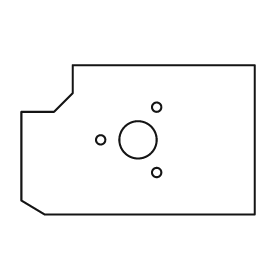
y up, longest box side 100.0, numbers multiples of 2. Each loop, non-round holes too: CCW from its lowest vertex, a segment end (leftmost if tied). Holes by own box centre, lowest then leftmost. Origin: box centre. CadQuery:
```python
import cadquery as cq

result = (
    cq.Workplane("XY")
    .moveTo(-40.0, -32.0)
    .lineTo(50.0, -32.0)
    .lineTo(50.0, 32.0)
    .lineTo(-28.0, 32.0)
    .lineTo(-28.0, 20.0)
    .lineTo(-36.0, 12.0)
    .lineTo(-50.0, 12.0)
    .lineTo(-50.0, -26.0)
    .close()
    .moveTo(8.0, -14.0)
    .circle(2.0)
    .moveTo(-16.0, 0.0)
    .circle(2.0)
    .moveTo(0.0, 0.0)
    .circle(8.0)
    .moveTo(8.0, 14.0)
    .circle(2.0)
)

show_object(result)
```